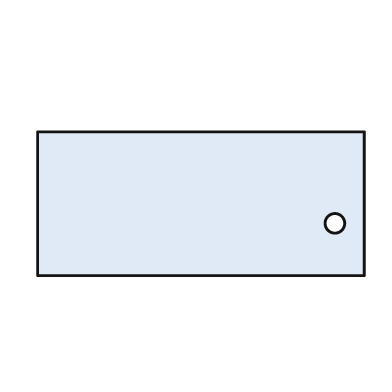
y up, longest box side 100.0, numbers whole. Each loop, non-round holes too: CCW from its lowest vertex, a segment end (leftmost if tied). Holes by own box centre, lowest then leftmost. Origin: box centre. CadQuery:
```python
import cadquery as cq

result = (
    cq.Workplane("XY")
    .moveTo(-50.0, -22.0)
    .lineTo(50.0, -22.0)
    .lineTo(50.0, 22.0)
    .lineTo(-50.0, 22.0)
    .close()
    .moveTo(41.0, -6.0)
    .circle(3.0)
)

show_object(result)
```